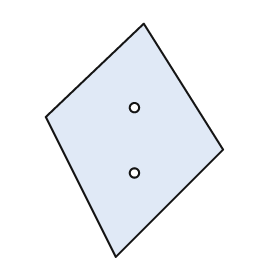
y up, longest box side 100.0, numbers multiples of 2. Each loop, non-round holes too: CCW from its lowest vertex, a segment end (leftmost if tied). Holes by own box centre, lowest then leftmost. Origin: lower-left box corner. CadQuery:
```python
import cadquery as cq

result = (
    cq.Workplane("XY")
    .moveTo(30.0, 0.0)
    .lineTo(76.0, 46.0)
    .lineTo(42.0, 100.0)
    .lineTo(0.0, 60.0)
    .close()
    .moveTo(38.0, 36.0)
    .circle(2.0)
    .moveTo(38.0, 64.0)
    .circle(2.0)
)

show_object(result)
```